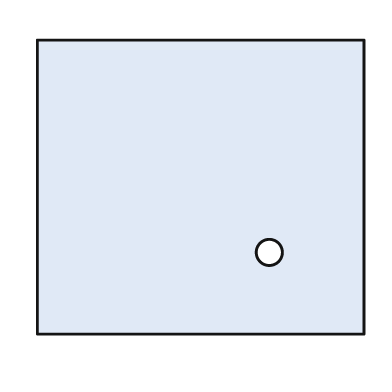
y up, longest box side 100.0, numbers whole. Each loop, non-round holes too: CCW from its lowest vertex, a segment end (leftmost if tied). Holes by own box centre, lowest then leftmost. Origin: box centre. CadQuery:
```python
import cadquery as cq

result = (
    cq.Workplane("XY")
    .moveTo(-50.0, -45.0)
    .lineTo(50.0, -45.0)
    .lineTo(50.0, 45.0)
    .lineTo(-50.0, 45.0)
    .close()
    .moveTo(21.0, -20.0)
    .circle(4.0)
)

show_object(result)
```